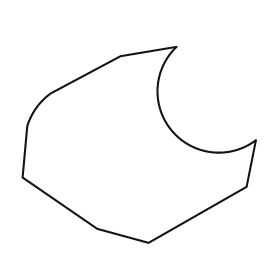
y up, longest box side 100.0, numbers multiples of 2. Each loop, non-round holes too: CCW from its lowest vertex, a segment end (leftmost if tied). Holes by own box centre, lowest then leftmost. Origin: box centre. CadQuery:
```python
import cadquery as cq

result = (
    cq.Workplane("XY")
    .moveTo(4.0, -42.0)
    .lineTo(46.0, -18.0)
    .lineTo(50.0, 2.0)
    .threePointArc((14.0, 6.0), (16.0, 42.0))
    .lineTo(-8.0, 38.0)
    .lineTo(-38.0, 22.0)
    .threePointArc((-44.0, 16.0), (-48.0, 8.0))
    .lineTo(-50.0, -14.0)
    .lineTo(-18.0, -36.0)
    .close()
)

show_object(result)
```